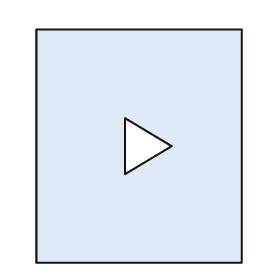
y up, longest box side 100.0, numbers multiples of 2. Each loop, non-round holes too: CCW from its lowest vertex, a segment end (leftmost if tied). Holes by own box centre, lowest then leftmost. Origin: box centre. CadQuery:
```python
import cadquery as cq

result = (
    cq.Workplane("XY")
    .moveTo(-44.0, -50.0)
    .lineTo(44.0, -50.0)
    .lineTo(44.0, 50.0)
    .lineTo(-44.0, 50.0)
    .close()
    .moveTo(-6.0, -12.0)
    .lineTo(14.0, 0.0)
    .lineTo(-6.0, 12.0)
    .close()
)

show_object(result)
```